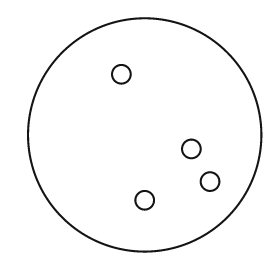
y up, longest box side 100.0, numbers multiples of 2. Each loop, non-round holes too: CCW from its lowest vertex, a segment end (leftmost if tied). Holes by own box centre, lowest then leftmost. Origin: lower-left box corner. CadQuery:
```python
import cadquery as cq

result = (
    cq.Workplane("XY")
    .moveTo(50.0, 50.0)
    .circle(50.0)
    .moveTo(50.0, 22.0)
    .circle(4.0)
    .moveTo(78.0, 30.0)
    .circle(4.0)
    .moveTo(70.0, 44.0)
    .circle(4.0)
    .moveTo(40.0, 76.0)
    .circle(4.0)
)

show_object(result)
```